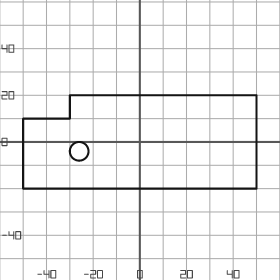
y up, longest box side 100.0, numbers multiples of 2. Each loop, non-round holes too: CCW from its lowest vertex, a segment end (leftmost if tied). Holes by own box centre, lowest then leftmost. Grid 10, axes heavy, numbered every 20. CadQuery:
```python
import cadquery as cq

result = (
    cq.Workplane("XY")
    .moveTo(-50.0, -20.0)
    .lineTo(50.0, -20.0)
    .lineTo(50.0, 20.0)
    .lineTo(-30.0, 20.0)
    .lineTo(-30.0, 10.0)
    .lineTo(-50.0, 10.0)
    .close()
    .moveTo(-26.0, -4.0)
    .circle(4.0)
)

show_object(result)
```